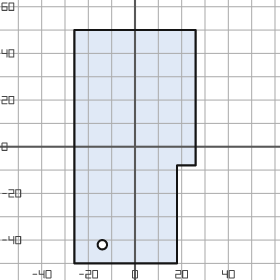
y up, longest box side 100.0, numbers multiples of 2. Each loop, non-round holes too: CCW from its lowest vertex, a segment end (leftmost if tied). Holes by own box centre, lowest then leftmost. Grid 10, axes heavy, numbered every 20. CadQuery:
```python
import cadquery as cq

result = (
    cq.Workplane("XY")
    .moveTo(-26.0, -50.0)
    .lineTo(18.0, -50.0)
    .lineTo(18.0, -8.0)
    .lineTo(26.0, -8.0)
    .lineTo(26.0, 50.0)
    .lineTo(-26.0, 50.0)
    .close()
    .moveTo(-14.0, -42.0)
    .circle(2.0)
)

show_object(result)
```